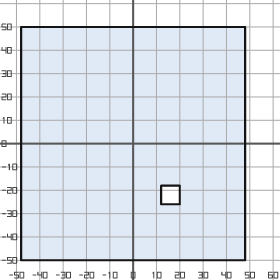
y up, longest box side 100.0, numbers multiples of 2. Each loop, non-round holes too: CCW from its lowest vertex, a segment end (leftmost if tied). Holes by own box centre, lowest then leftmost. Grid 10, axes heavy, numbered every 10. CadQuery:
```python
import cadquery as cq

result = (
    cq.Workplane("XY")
    .moveTo(-48.0, -50.0)
    .lineTo(48.0, -50.0)
    .lineTo(48.0, 50.0)
    .lineTo(-48.0, 50.0)
    .close()
    .moveTo(12.0, -26.0)
    .lineTo(20.0, -26.0)
    .lineTo(20.0, -18.0)
    .lineTo(12.0, -18.0)
    .close()
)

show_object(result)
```